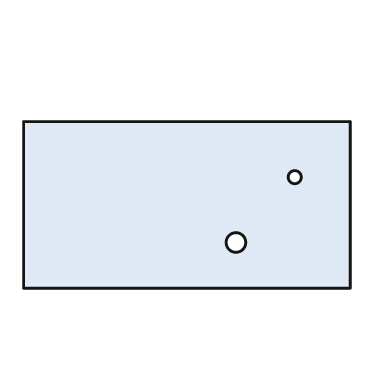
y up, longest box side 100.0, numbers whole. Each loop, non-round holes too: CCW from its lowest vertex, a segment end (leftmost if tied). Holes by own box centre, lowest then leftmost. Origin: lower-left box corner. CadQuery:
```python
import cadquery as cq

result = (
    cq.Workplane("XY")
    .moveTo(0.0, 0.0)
    .lineTo(100.0, 0.0)
    .lineTo(100.0, 51.0)
    .lineTo(0.0, 51.0)
    .close()
    .moveTo(65.0, 14.0)
    .circle(3.0)
    .moveTo(83.0, 34.0)
    .circle(2.0)
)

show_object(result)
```